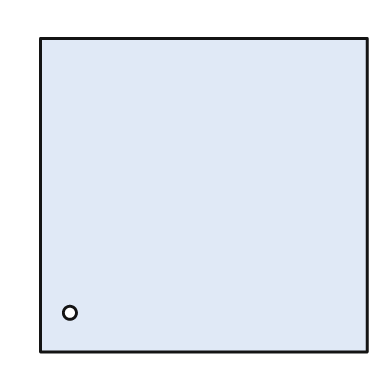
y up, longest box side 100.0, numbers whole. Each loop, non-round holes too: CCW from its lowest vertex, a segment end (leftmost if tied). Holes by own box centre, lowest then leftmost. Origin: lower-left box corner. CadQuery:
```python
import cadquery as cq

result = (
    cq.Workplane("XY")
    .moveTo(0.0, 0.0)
    .lineTo(100.0, 0.0)
    .lineTo(100.0, 96.0)
    .lineTo(0.0, 96.0)
    .close()
    .moveTo(9.0, 12.0)
    .circle(2.0)
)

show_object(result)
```